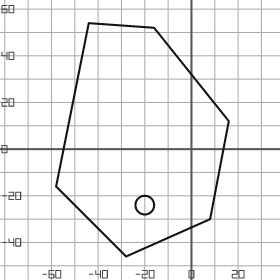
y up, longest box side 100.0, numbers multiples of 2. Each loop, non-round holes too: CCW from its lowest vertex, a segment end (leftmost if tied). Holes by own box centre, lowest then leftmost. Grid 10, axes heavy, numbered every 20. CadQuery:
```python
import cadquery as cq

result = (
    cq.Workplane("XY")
    .moveTo(-28.0, -46.0)
    .lineTo(8.0, -30.0)
    .lineTo(16.0, 12.0)
    .lineTo(-16.0, 52.0)
    .lineTo(-44.0, 54.0)
    .lineTo(-58.0, -16.0)
    .close()
    .moveTo(-20.0, -24.0)
    .circle(4.0)
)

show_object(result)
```